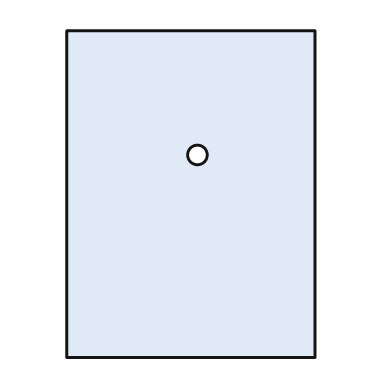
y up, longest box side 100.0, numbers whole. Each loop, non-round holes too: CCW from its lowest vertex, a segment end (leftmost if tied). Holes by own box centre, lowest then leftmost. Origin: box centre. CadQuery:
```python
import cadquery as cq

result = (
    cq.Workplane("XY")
    .moveTo(-38.0, -50.0)
    .lineTo(38.0, -50.0)
    .lineTo(38.0, 50.0)
    .lineTo(-38.0, 50.0)
    .close()
    .moveTo(2.0, 12.0)
    .circle(3.0)
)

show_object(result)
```